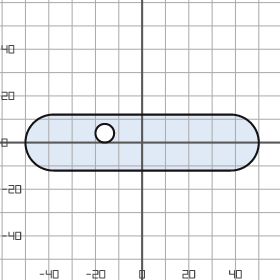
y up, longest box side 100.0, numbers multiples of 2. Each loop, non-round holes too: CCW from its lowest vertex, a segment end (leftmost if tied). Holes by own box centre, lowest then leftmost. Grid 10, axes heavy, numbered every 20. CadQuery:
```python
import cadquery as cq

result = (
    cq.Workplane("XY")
    .moveTo(-38.0, -12.0)
    .lineTo(38.0, -12.0)
    .threePointArc((50.0, 0.0), (38.0, 12.0))
    .lineTo(-38.0, 12.0)
    .threePointArc((-50.0, 0.0), (-38.0, -12.0))
    .close()
    .moveTo(-16.0, 4.0)
    .circle(4.0)
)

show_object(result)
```